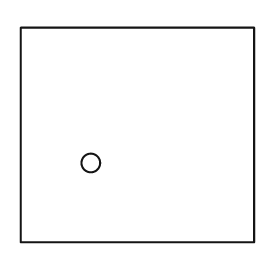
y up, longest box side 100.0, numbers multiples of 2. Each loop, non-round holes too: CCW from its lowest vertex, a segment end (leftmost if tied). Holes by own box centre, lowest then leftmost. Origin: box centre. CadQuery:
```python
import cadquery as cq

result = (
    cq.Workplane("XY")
    .moveTo(-50.0, -46.0)
    .lineTo(50.0, -46.0)
    .lineTo(50.0, 46.0)
    .lineTo(-50.0, 46.0)
    .close()
    .moveTo(-20.0, -12.0)
    .circle(4.0)
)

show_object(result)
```